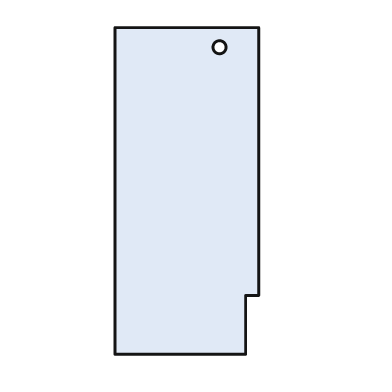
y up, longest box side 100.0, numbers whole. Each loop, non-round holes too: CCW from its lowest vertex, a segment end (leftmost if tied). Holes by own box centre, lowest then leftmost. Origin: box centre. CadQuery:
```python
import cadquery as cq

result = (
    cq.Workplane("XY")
    .moveTo(-22.0, -50.0)
    .lineTo(18.0, -50.0)
    .lineTo(18.0, -32.0)
    .lineTo(22.0, -32.0)
    .lineTo(22.0, 50.0)
    .lineTo(-22.0, 50.0)
    .close()
    .moveTo(10.0, 44.0)
    .circle(2.0)
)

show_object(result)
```